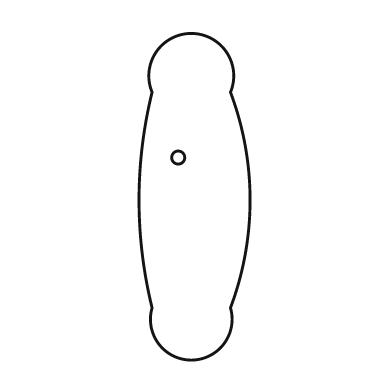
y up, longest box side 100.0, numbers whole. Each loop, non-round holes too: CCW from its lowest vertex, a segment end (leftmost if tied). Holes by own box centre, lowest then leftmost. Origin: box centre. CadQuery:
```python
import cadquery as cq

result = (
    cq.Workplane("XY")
    .moveTo(-13.0, -34.0)
    .threePointArc((-1.0, -50.0), (11.0, -34.0))
    .threePointArc((17.0, -1.0), (11.0, 32.0))
    .threePointArc((-1.0, 50.0), (-13.0, 32.0))
    .threePointArc((-17.0, -1.0), (-13.0, -34.0))
    .close()
    .moveTo(-5.0, 12.0)
    .circle(2.0)
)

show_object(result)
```